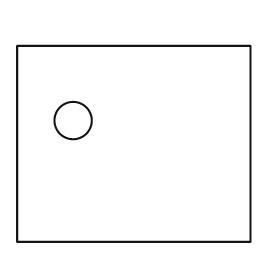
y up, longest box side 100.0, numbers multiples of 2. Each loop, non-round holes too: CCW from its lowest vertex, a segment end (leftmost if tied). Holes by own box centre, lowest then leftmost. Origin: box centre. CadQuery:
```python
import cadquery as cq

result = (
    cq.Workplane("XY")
    .moveTo(-50.0, -42.0)
    .lineTo(50.0, -42.0)
    .lineTo(50.0, 42.0)
    .lineTo(-50.0, 42.0)
    .close()
    .moveTo(-26.0, 10.0)
    .circle(8.0)
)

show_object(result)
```